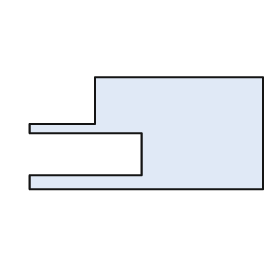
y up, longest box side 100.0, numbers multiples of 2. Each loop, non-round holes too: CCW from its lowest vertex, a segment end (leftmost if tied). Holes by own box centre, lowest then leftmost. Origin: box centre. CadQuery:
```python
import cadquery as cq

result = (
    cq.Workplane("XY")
    .moveTo(-50.0, -24.0)
    .lineTo(50.0, -24.0)
    .lineTo(50.0, 24.0)
    .lineTo(-22.0, 24.0)
    .lineTo(-22.0, 4.0)
    .lineTo(-50.0, 4.0)
    .lineTo(-50.0, 0.0)
    .lineTo(-2.0, 0.0)
    .lineTo(-2.0, -18.0)
    .lineTo(-50.0, -18.0)
    .close()
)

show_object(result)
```